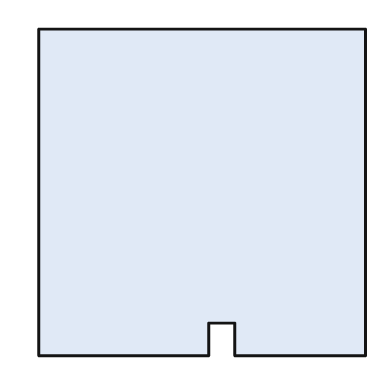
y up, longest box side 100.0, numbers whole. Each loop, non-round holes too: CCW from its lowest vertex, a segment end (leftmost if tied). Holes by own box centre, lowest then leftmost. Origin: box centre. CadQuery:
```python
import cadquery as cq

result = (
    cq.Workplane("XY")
    .moveTo(-50.0, -50.0)
    .lineTo(2.0, -50.0)
    .lineTo(2.0, -40.0)
    .lineTo(10.0, -40.0)
    .lineTo(10.0, -50.0)
    .lineTo(50.0, -50.0)
    .lineTo(50.0, 50.0)
    .lineTo(-50.0, 50.0)
    .close()
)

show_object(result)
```